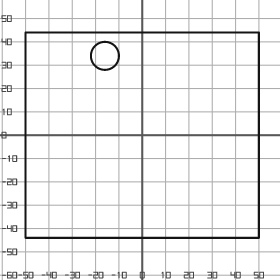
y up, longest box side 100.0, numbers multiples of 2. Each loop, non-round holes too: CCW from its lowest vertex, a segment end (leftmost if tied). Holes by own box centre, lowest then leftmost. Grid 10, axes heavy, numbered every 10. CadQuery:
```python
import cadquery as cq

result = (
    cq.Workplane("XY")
    .moveTo(-50.0, -44.0)
    .lineTo(50.0, -44.0)
    .lineTo(50.0, 44.0)
    .lineTo(-50.0, 44.0)
    .close()
    .moveTo(-16.0, 34.0)
    .circle(6.0)
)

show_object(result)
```